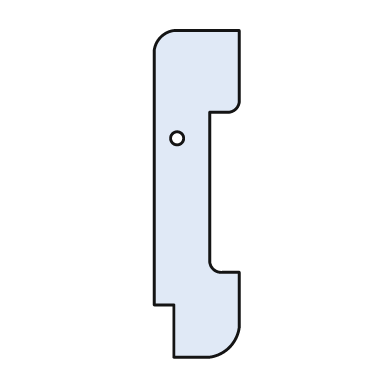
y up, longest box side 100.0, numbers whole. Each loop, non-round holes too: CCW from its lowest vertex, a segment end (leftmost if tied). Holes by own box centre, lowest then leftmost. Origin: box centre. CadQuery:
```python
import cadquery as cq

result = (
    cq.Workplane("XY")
    .moveTo(-7.0, -50.0)
    .lineTo(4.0, -50.0)
    .threePointArc((10.0, -47.0), (13.0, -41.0))
    .lineTo(13.0, -24.0)
    .lineTo(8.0, -24.0)
    .threePointArc((5.0, -23.0), (4.0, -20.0))
    .lineTo(4.0, 25.0)
    .lineTo(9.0, 25.0)
    .threePointArc((12.0, 26.0), (13.0, 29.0))
    .lineTo(13.0, 50.0)
    .lineTo(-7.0, 50.0)
    .threePointArc((-11.0, 48.0), (-13.0, 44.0))
    .lineTo(-13.0, -34.0)
    .lineTo(-7.0, -34.0)
    .close()
    .moveTo(-6.0, 17.0)
    .circle(2.0)
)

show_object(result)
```